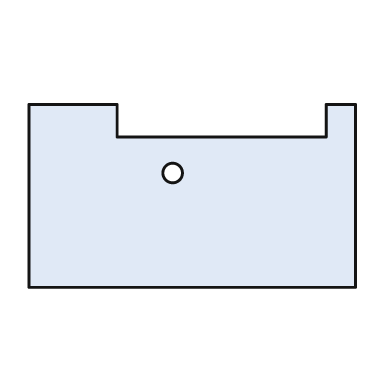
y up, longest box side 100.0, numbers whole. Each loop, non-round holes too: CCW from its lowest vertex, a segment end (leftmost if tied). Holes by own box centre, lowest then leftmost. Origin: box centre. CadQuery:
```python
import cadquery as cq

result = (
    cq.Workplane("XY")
    .moveTo(-50.0, -28.0)
    .lineTo(50.0, -28.0)
    .lineTo(50.0, 28.0)
    .lineTo(41.0, 28.0)
    .lineTo(41.0, 18.0)
    .lineTo(-23.0, 18.0)
    .lineTo(-23.0, 28.0)
    .lineTo(-50.0, 28.0)
    .close()
    .moveTo(-6.0, 7.0)
    .circle(3.0)
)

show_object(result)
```